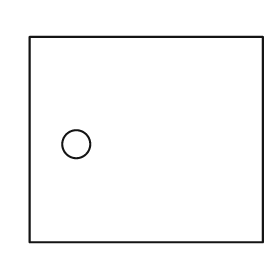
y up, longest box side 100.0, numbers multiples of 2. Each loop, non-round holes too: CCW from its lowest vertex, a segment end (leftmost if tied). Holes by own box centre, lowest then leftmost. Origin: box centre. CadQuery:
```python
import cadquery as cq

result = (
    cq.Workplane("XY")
    .moveTo(-50.0, -44.0)
    .lineTo(50.0, -44.0)
    .lineTo(50.0, 44.0)
    .lineTo(-50.0, 44.0)
    .close()
    .moveTo(-30.0, -2.0)
    .circle(6.0)
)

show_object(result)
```